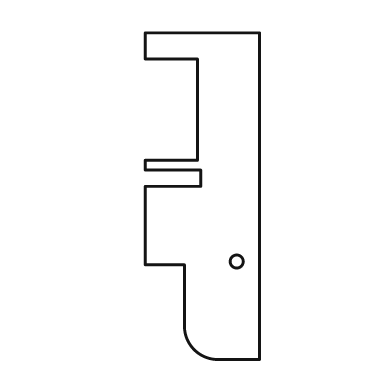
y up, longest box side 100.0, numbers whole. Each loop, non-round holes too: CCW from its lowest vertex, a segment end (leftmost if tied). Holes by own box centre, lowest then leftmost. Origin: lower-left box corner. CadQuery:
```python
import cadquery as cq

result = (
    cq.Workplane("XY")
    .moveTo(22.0, 0.0)
    .lineTo(35.0, 0.0)
    .lineTo(35.0, 100.0)
    .lineTo(0.0, 100.0)
    .lineTo(0.0, 92.0)
    .lineTo(16.0, 92.0)
    .lineTo(16.0, 61.0)
    .lineTo(0.0, 61.0)
    .lineTo(0.0, 58.0)
    .lineTo(17.0, 58.0)
    .lineTo(17.0, 53.0)
    .lineTo(0.0, 53.0)
    .lineTo(0.0, 29.0)
    .lineTo(12.0, 29.0)
    .lineTo(12.0, 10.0)
    .threePointArc((15.0, 3.0), (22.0, 0.0))
    .close()
    .moveTo(28.0, 30.0)
    .circle(2.0)
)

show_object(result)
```